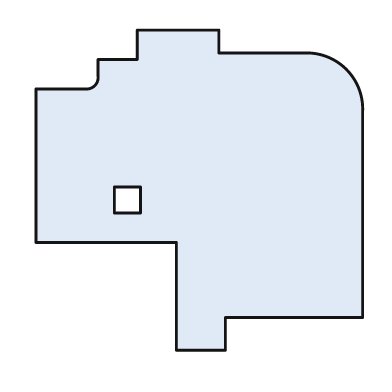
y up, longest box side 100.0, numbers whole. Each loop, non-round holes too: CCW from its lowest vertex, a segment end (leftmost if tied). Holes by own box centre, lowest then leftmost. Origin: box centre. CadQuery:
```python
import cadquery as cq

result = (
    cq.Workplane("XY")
    .moveTo(-7.0, -49.0)
    .lineTo(8.0, -49.0)
    .lineTo(8.0, -39.0)
    .lineTo(50.0, -39.0)
    .lineTo(50.0, 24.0)
    .threePointArc((45.0, 37.0), (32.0, 42.0))
    .lineTo(6.0, 42.0)
    .lineTo(6.0, 49.0)
    .lineTo(-19.0, 49.0)
    .lineTo(-19.0, 40.0)
    .lineTo(-31.0, 40.0)
    .lineTo(-31.0, 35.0)
    .threePointArc((-32.0, 32.0), (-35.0, 31.0))
    .lineTo(-50.0, 31.0)
    .lineTo(-50.0, -16.0)
    .lineTo(-7.0, -16.0)
    .close()
    .moveTo(-26.0, -7.0)
    .lineTo(-18.0, -7.0)
    .lineTo(-18.0, 1.0)
    .lineTo(-26.0, 1.0)
    .close()
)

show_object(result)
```